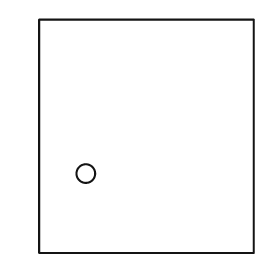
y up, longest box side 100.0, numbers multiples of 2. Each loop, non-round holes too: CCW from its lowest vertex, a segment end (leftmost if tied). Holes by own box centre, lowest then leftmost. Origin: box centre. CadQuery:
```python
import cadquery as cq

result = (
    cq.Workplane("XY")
    .moveTo(-46.0, -50.0)
    .lineTo(46.0, -50.0)
    .lineTo(46.0, 50.0)
    .lineTo(-46.0, 50.0)
    .close()
    .moveTo(-26.0, -16.0)
    .circle(4.0)
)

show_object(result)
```